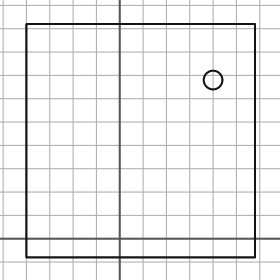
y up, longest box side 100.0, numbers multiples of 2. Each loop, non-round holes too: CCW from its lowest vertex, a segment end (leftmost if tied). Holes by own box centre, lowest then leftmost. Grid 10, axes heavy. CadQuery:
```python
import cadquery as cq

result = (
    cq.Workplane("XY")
    .moveTo(-40.0, -8.0)
    .lineTo(58.0, -8.0)
    .lineTo(58.0, 92.0)
    .lineTo(-40.0, 92.0)
    .close()
    .moveTo(40.0, 68.0)
    .circle(4.0)
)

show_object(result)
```